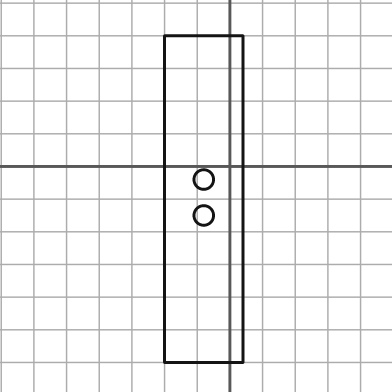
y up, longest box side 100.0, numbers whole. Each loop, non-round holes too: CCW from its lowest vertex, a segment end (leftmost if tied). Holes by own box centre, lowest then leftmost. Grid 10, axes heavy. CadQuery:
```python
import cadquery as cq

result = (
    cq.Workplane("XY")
    .moveTo(-20.0, -60.0)
    .lineTo(4.0, -60.0)
    .lineTo(4.0, 40.0)
    .lineTo(-20.0, 40.0)
    .close()
    .moveTo(-8.0, -15.0)
    .circle(3.0)
    .moveTo(-8.0, -4.0)
    .circle(3.0)
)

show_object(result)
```